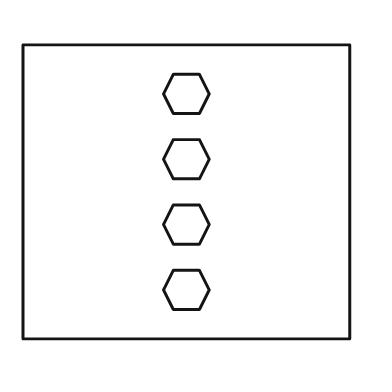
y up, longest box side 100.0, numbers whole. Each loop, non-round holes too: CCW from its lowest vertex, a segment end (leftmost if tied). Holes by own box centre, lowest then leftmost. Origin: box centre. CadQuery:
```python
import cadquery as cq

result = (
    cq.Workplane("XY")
    .moveTo(-50.0, -45.0)
    .lineTo(50.0, -45.0)
    .lineTo(50.0, 45.0)
    .lineTo(-50.0, 45.0)
    .close()
    .moveTo(-4.0, -36.0)
    .lineTo(4.0, -36.0)
    .lineTo(7.0, -30.0)
    .lineTo(4.0, -24.0)
    .lineTo(-4.0, -24.0)
    .lineTo(-7.0, -30.0)
    .close()
    .moveTo(-4.0, -16.0)
    .lineTo(4.0, -16.0)
    .lineTo(7.0, -10.0)
    .lineTo(4.0, -4.0)
    .lineTo(-4.0, -4.0)
    .lineTo(-7.0, -10.0)
    .close()
    .moveTo(-4.0, 4.0)
    .lineTo(4.0, 4.0)
    .lineTo(7.0, 10.0)
    .lineTo(4.0, 16.0)
    .lineTo(-4.0, 16.0)
    .lineTo(-7.0, 10.0)
    .close()
    .moveTo(-4.0, 24.0)
    .lineTo(4.0, 24.0)
    .lineTo(7.0, 30.0)
    .lineTo(4.0, 36.0)
    .lineTo(-4.0, 36.0)
    .lineTo(-7.0, 30.0)
    .close()
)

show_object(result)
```